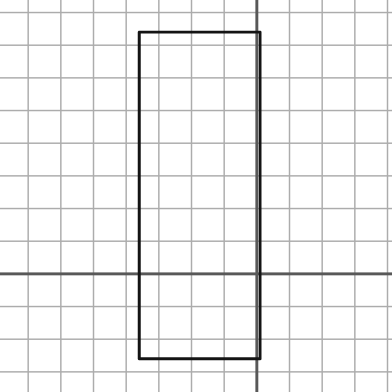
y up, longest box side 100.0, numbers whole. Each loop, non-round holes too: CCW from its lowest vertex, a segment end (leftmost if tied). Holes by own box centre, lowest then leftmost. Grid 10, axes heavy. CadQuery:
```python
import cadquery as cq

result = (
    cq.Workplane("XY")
    .moveTo(-36.0, -26.0)
    .lineTo(1.0, -26.0)
    .lineTo(1.0, 74.0)
    .lineTo(-36.0, 74.0)
    .close()
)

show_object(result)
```